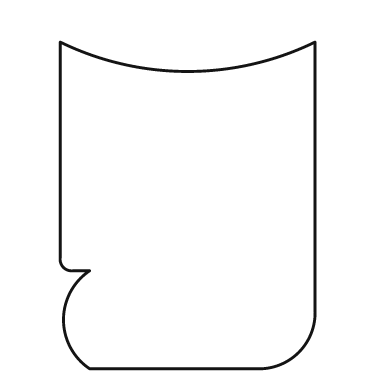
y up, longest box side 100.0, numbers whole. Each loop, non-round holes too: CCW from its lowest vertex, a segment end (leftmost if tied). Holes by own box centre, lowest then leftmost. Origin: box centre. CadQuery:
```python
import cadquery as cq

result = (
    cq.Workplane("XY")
    .moveTo(-30.0, -50.0)
    .lineTo(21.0, -50.0)
    .threePointArc((34.0, -45.0), (39.0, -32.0))
    .lineTo(39.0, 50.0)
    .threePointArc((0.0, 41.0), (-39.0, 50.0))
    .lineTo(-39.0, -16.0)
    .threePointArc((-38.0, -19.0), (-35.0, -20.0))
    .lineTo(-30.0, -20.0)
    .threePointArc((-38.0, -35.0), (-30.0, -50.0))
    .close()
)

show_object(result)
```